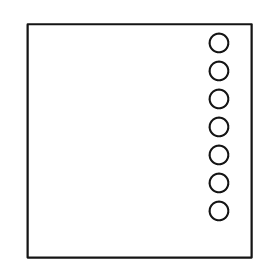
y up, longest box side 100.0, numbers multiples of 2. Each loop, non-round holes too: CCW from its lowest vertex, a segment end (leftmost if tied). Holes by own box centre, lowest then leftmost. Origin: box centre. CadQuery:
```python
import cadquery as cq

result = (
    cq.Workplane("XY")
    .moveTo(-48.0, -50.0)
    .lineTo(48.0, -50.0)
    .lineTo(48.0, 50.0)
    .lineTo(-48.0, 50.0)
    .close()
    .moveTo(34.0, -30.0)
    .circle(4.0)
    .moveTo(34.0, -18.0)
    .circle(4.0)
    .moveTo(34.0, -6.0)
    .circle(4.0)
    .moveTo(34.0, 6.0)
    .circle(4.0)
    .moveTo(34.0, 18.0)
    .circle(4.0)
    .moveTo(34.0, 30.0)
    .circle(4.0)
    .moveTo(34.0, 42.0)
    .circle(4.0)
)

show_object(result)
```